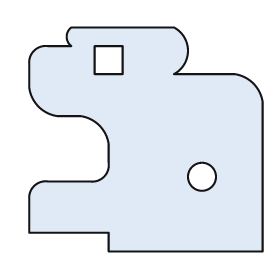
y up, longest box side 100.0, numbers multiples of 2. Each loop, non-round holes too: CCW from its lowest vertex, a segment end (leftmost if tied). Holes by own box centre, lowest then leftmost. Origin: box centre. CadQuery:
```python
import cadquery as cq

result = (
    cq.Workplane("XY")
    .moveTo(-16.0, -48.0)
    .lineTo(50.0, -48.0)
    .lineTo(50.0, 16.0)
    .threePointArc((46.0, 24.0), (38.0, 28.0))
    .lineTo(12.0, 28.0)
    .threePointArc((18.0, 38.0), (12.0, 48.0))
    .lineTo(-32.0, 48.0)
    .threePointArc((-34.0, 44.0), (-32.0, 40.0))
    .lineTo(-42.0, 40.0)
    .threePointArc((-48.0, 38.0), (-50.0, 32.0))
    .lineTo(-50.0, 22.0)
    .threePointArc((-46.0, 14.0), (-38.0, 10.0))
    .lineTo(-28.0, 10.0)
    .threePointArc((-20.0, 6.0), (-16.0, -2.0))
    .lineTo(-16.0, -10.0)
    .threePointArc((-18.0, -16.0), (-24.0, -18.0))
    .lineTo(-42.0, -18.0)
    .threePointArc((-48.0, -20.0), (-50.0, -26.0))
    .lineTo(-50.0, -40.0)
    .lineTo(-16.0, -40.0)
    .close()
    .moveTo(24.0, -16.0)
    .circle(6.0)
    .moveTo(-22.0, 28.0)
    .lineTo(-10.0, 28.0)
    .lineTo(-10.0, 40.0)
    .lineTo(-22.0, 40.0)
    .close()
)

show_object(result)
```